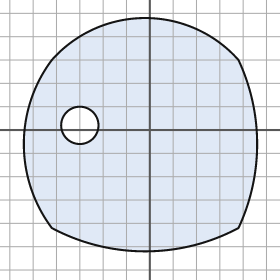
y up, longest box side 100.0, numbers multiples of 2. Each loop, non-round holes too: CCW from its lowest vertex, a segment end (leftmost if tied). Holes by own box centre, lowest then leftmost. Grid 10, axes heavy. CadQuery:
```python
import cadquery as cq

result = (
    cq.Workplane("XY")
    .moveTo(-42.0, -42.0)
    .threePointArc((-2.0, -52.0), (38.0, -42.0))
    .threePointArc((46.0, -6.0), (38.0, 30.0))
    .threePointArc((-2.0, 48.0), (-42.0, 30.0))
    .threePointArc((-54.0, -6.0), (-42.0, -42.0))
    .close()
    .moveTo(-30.0, 2.0)
    .circle(8.0)
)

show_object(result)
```